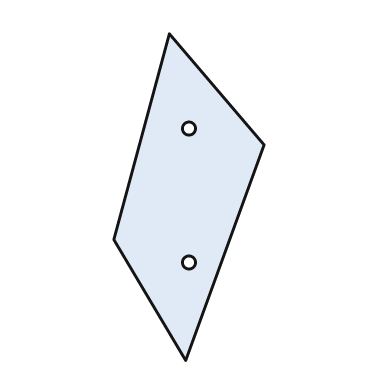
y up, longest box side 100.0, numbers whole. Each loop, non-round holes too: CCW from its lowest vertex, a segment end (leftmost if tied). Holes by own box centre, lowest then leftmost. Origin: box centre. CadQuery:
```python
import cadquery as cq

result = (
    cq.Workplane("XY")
    .moveTo(-1.0, -50.0)
    .lineTo(23.0, 16.0)
    .lineTo(-6.0, 50.0)
    .lineTo(-23.0, -13.0)
    .close()
    .moveTo(0.0, -20.0)
    .circle(2.0)
    .moveTo(0.0, 21.0)
    .circle(2.0)
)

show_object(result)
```